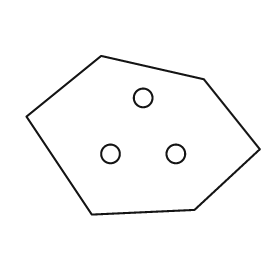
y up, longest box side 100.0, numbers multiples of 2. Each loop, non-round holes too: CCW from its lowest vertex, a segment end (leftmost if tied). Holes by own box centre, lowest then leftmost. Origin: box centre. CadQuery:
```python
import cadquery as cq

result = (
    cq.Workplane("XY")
    .moveTo(-22.0, -34.0)
    .lineTo(22.0, -32.0)
    .lineTo(50.0, -6.0)
    .lineTo(26.0, 24.0)
    .lineTo(-18.0, 34.0)
    .lineTo(-50.0, 8.0)
    .close()
    .moveTo(-14.0, -8.0)
    .circle(4.0)
    .moveTo(14.0, -8.0)
    .circle(4.0)
    .moveTo(0.0, 16.0)
    .circle(4.0)
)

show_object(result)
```